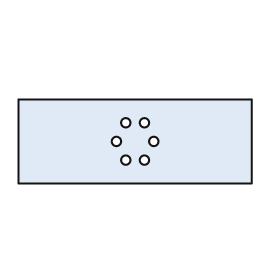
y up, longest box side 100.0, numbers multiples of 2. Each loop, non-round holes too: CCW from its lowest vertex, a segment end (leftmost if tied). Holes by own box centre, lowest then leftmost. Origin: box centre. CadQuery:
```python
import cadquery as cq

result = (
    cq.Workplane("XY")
    .moveTo(-50.0, -18.0)
    .lineTo(50.0, -18.0)
    .lineTo(50.0, 18.0)
    .lineTo(-50.0, 18.0)
    .close()
    .moveTo(-4.0, -8.0)
    .circle(2.0)
    .moveTo(4.0, -8.0)
    .circle(2.0)
    .moveTo(-8.0, 0.0)
    .circle(2.0)
    .moveTo(8.0, 0.0)
    .circle(2.0)
    .moveTo(-4.0, 8.0)
    .circle(2.0)
    .moveTo(4.0, 8.0)
    .circle(2.0)
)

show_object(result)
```